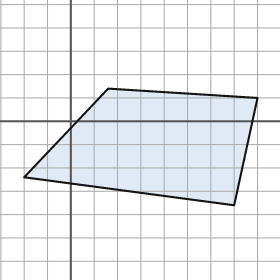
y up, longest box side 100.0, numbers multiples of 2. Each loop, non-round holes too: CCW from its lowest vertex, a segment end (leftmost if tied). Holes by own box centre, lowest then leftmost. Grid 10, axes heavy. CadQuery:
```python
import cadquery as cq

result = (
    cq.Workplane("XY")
    .moveTo(70.0, -36.0)
    .lineTo(80.0, 10.0)
    .lineTo(16.0, 14.0)
    .lineTo(-20.0, -24.0)
    .close()
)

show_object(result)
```